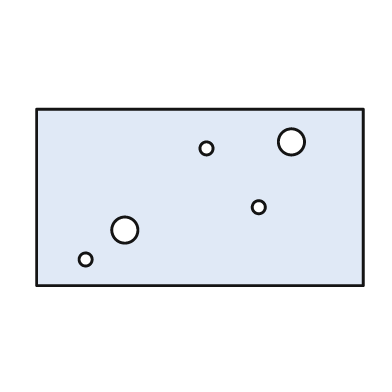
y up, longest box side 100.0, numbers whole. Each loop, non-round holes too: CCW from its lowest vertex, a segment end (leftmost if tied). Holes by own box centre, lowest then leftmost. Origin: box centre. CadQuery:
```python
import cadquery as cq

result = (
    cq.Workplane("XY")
    .moveTo(-50.0, -27.0)
    .lineTo(50.0, -27.0)
    .lineTo(50.0, 27.0)
    .lineTo(-50.0, 27.0)
    .close()
    .moveTo(-35.0, -19.0)
    .circle(2.0)
    .moveTo(-23.0, -10.0)
    .circle(4.0)
    .moveTo(18.0, -3.0)
    .circle(2.0)
    .moveTo(2.0, 15.0)
    .circle(2.0)
    .moveTo(28.0, 17.0)
    .circle(4.0)
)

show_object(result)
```